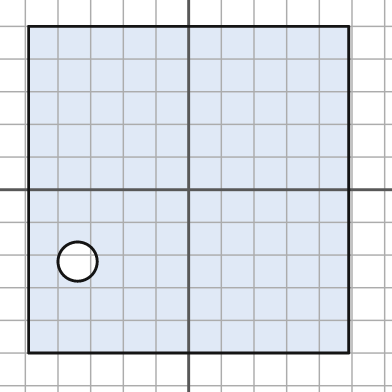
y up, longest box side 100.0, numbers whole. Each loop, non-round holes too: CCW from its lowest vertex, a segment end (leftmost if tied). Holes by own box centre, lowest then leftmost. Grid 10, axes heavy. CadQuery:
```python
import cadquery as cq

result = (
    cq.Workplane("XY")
    .moveTo(-49.0, -50.0)
    .lineTo(49.0, -50.0)
    .lineTo(49.0, 50.0)
    .lineTo(-49.0, 50.0)
    .close()
    .moveTo(-34.0, -22.0)
    .circle(6.0)
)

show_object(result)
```